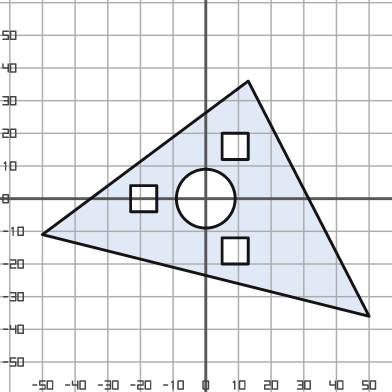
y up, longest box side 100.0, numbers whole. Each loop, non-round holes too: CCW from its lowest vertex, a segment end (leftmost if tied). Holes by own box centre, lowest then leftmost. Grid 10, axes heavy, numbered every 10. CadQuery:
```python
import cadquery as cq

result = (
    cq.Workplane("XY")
    .moveTo(50.0, -36.0)
    .lineTo(13.0, 36.0)
    .lineTo(-50.0, -11.0)
    .close()
    .moveTo(5.0, -20.0)
    .lineTo(13.0, -20.0)
    .lineTo(13.0, -12.0)
    .lineTo(5.0, -12.0)
    .close()
    .moveTo(-23.0, -4.0)
    .lineTo(-15.0, -4.0)
    .lineTo(-15.0, 4.0)
    .lineTo(-23.0, 4.0)
    .close()
    .moveTo(0.0, 0.0)
    .circle(9.0)
    .moveTo(5.0, 12.0)
    .lineTo(13.0, 12.0)
    .lineTo(13.0, 20.0)
    .lineTo(5.0, 20.0)
    .close()
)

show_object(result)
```